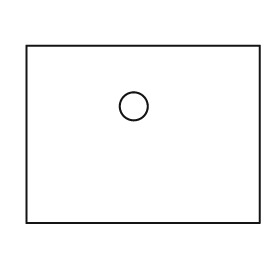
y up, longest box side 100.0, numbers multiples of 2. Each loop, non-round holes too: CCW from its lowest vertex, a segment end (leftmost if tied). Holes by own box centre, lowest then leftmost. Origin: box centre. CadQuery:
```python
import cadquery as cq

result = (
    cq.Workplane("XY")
    .moveTo(-50.0, -38.0)
    .lineTo(50.0, -38.0)
    .lineTo(50.0, 38.0)
    .lineTo(-50.0, 38.0)
    .close()
    .moveTo(-4.0, 12.0)
    .circle(6.0)
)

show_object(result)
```